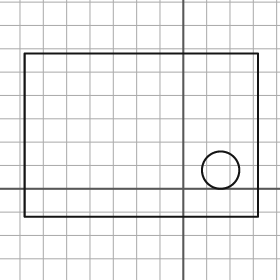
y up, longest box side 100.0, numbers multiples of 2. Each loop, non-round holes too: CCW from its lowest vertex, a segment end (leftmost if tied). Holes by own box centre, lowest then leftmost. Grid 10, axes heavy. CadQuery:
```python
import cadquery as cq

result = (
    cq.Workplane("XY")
    .moveTo(-68.0, -12.0)
    .lineTo(32.0, -12.0)
    .lineTo(32.0, 58.0)
    .lineTo(-68.0, 58.0)
    .close()
    .moveTo(16.0, 8.0)
    .circle(8.0)
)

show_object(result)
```